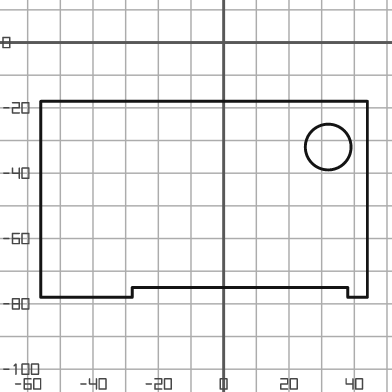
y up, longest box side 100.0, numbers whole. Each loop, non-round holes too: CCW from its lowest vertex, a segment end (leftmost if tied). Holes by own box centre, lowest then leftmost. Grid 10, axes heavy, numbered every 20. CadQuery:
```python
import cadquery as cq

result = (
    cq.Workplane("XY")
    .moveTo(-56.0, -78.0)
    .lineTo(-28.0, -78.0)
    .lineTo(-28.0, -75.0)
    .lineTo(38.0, -75.0)
    .lineTo(38.0, -78.0)
    .lineTo(44.0, -78.0)
    .lineTo(44.0, -18.0)
    .lineTo(-56.0, -18.0)
    .close()
    .moveTo(32.0, -32.0)
    .circle(7.0)
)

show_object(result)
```